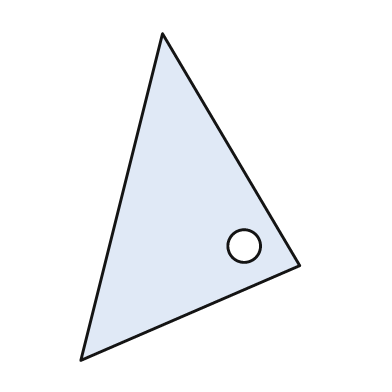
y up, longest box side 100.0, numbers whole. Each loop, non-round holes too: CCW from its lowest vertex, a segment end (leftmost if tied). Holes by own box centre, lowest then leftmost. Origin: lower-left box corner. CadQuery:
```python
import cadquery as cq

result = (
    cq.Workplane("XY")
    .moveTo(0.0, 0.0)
    .lineTo(67.0, 29.0)
    .lineTo(25.0, 100.0)
    .close()
    .moveTo(50.0, 35.0)
    .circle(5.0)
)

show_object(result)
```